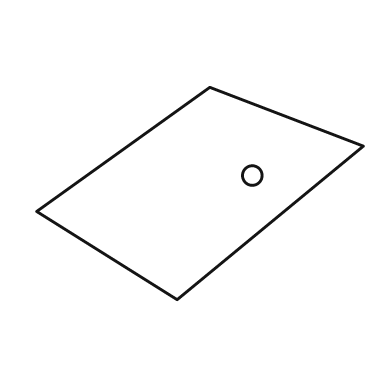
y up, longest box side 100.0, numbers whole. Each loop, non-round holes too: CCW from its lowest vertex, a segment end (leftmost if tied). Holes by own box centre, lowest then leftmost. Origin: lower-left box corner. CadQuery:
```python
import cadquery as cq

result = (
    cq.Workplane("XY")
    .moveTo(43.0, 0.0)
    .lineTo(100.0, 47.0)
    .lineTo(53.0, 65.0)
    .lineTo(0.0, 27.0)
    .close()
    .moveTo(66.0, 38.0)
    .circle(3.0)
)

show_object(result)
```